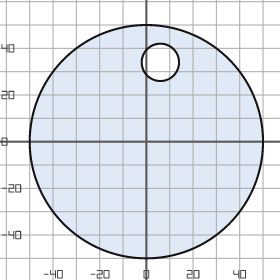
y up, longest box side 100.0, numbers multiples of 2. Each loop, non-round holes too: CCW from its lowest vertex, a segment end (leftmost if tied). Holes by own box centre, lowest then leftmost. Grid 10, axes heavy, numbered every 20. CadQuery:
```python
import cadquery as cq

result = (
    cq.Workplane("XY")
    .moveTo(0.0, 0.0)
    .circle(50.0)
    .moveTo(6.0, 34.0)
    .circle(8.0)
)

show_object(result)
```